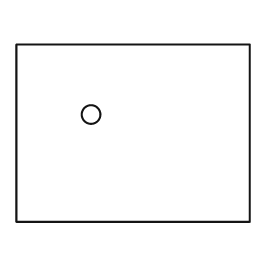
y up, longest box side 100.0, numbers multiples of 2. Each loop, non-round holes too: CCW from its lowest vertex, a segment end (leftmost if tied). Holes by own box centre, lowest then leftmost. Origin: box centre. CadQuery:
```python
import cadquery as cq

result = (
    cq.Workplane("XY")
    .moveTo(-50.0, -38.0)
    .lineTo(50.0, -38.0)
    .lineTo(50.0, 38.0)
    .lineTo(-50.0, 38.0)
    .close()
    .moveTo(-18.0, 8.0)
    .circle(4.0)
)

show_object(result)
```